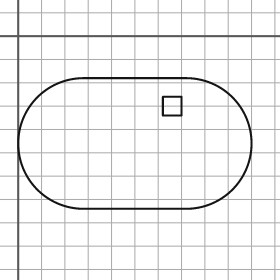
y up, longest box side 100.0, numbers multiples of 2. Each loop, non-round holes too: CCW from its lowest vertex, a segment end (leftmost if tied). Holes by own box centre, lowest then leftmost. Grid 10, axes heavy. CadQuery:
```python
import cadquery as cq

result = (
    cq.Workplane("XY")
    .moveTo(28.0, -74.0)
    .lineTo(72.0, -74.0)
    .threePointArc((100.0, -46.0), (72.0, -18.0))
    .lineTo(28.0, -18.0)
    .threePointArc((0.0, -46.0), (28.0, -74.0))
    .close()
    .moveTo(62.0, -34.0)
    .lineTo(70.0, -34.0)
    .lineTo(70.0, -26.0)
    .lineTo(62.0, -26.0)
    .close()
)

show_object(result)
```